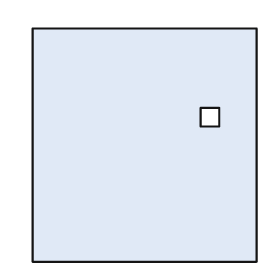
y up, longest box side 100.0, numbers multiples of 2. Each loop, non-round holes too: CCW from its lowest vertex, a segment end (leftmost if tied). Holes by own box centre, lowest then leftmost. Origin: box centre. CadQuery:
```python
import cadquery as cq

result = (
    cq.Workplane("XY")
    .moveTo(-48.0, -50.0)
    .lineTo(48.0, -50.0)
    .lineTo(48.0, 50.0)
    .lineTo(-48.0, 50.0)
    .close()
    .moveTo(24.0, 8.0)
    .lineTo(32.0, 8.0)
    .lineTo(32.0, 16.0)
    .lineTo(24.0, 16.0)
    .close()
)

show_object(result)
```